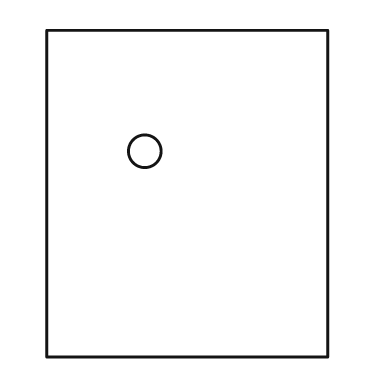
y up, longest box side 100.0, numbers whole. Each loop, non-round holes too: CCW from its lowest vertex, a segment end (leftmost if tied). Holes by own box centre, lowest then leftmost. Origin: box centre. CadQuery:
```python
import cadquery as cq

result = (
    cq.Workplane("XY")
    .moveTo(-43.0, -50.0)
    .lineTo(43.0, -50.0)
    .lineTo(43.0, 50.0)
    .lineTo(-43.0, 50.0)
    .close()
    .moveTo(-13.0, 13.0)
    .circle(5.0)
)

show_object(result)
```